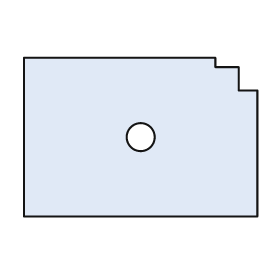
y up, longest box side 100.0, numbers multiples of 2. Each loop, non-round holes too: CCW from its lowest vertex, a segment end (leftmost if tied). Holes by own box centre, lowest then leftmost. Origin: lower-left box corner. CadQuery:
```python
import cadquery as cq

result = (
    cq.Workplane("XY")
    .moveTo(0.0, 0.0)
    .lineTo(100.0, 0.0)
    .lineTo(100.0, 54.0)
    .lineTo(92.0, 54.0)
    .lineTo(92.0, 64.0)
    .lineTo(82.0, 64.0)
    .lineTo(82.0, 68.0)
    .lineTo(0.0, 68.0)
    .close()
    .moveTo(50.0, 34.0)
    .circle(6.0)
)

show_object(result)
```